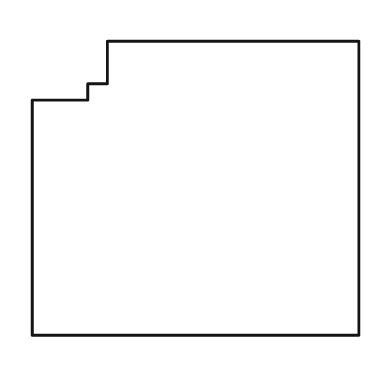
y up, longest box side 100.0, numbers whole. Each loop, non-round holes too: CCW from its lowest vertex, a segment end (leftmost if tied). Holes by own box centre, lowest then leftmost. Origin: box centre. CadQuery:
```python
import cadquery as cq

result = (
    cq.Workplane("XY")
    .moveTo(-50.0, -45.0)
    .lineTo(50.0, -45.0)
    .lineTo(50.0, 45.0)
    .lineTo(-27.0, 45.0)
    .lineTo(-27.0, 32.0)
    .lineTo(-33.0, 32.0)
    .lineTo(-33.0, 27.0)
    .lineTo(-50.0, 27.0)
    .close()
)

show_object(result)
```